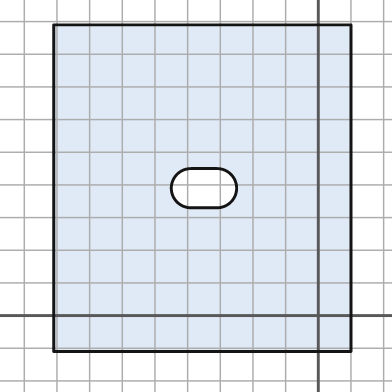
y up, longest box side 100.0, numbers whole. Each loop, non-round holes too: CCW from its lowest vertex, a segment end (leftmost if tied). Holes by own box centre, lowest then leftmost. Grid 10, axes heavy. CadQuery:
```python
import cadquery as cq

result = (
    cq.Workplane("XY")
    .moveTo(-81.0, -11.0)
    .lineTo(10.0, -11.0)
    .lineTo(10.0, 89.0)
    .lineTo(-81.0, 89.0)
    .close()
    .moveTo(-39.0, 33.0)
    .lineTo(-31.0, 33.0)
    .threePointArc((-25.0, 39.0), (-31.0, 45.0))
    .lineTo(-39.0, 45.0)
    .threePointArc((-45.0, 39.0), (-39.0, 33.0))
    .close()
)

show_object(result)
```